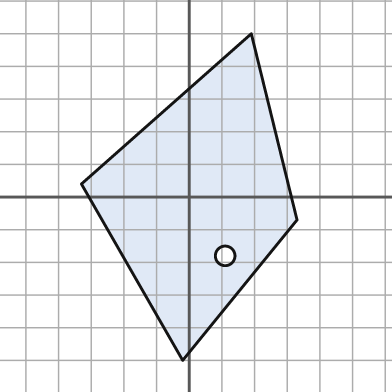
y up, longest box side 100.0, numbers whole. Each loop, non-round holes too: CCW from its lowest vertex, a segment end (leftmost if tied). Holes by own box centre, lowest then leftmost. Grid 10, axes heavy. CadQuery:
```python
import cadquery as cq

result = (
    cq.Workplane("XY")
    .moveTo(-2.0, -50.0)
    .lineTo(33.0, -7.0)
    .lineTo(19.0, 50.0)
    .lineTo(-33.0, 4.0)
    .close()
    .moveTo(11.0, -18.0)
    .circle(3.0)
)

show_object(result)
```